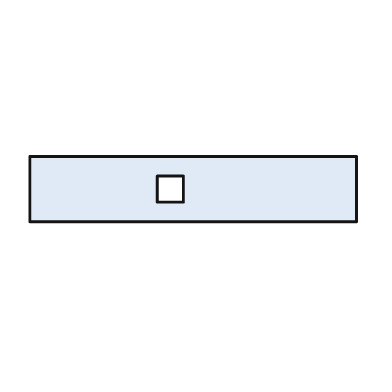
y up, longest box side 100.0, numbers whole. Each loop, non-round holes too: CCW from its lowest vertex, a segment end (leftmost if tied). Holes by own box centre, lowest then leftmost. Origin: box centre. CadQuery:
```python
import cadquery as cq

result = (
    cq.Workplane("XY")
    .moveTo(-50.0, -10.0)
    .lineTo(50.0, -10.0)
    .lineTo(50.0, 10.0)
    .lineTo(-50.0, 10.0)
    .close()
    .moveTo(-11.0, -4.0)
    .lineTo(-3.0, -4.0)
    .lineTo(-3.0, 4.0)
    .lineTo(-11.0, 4.0)
    .close()
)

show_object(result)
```